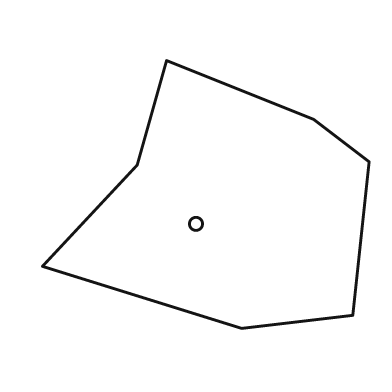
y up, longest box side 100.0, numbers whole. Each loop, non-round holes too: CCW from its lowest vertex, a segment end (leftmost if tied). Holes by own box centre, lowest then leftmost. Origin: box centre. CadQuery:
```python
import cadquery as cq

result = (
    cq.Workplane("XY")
    .moveTo(11.0, -41.0)
    .lineTo(45.0, -37.0)
    .lineTo(50.0, 10.0)
    .lineTo(33.0, 23.0)
    .lineTo(-12.0, 41.0)
    .lineTo(-21.0, 9.0)
    .lineTo(-50.0, -22.0)
    .close()
    .moveTo(-3.0, -9.0)
    .circle(2.0)
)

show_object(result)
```